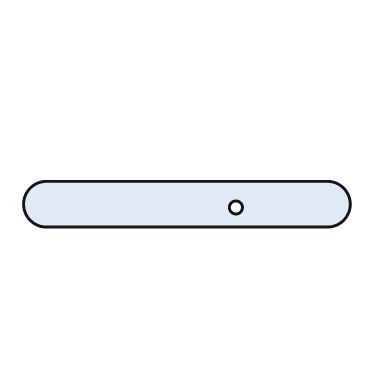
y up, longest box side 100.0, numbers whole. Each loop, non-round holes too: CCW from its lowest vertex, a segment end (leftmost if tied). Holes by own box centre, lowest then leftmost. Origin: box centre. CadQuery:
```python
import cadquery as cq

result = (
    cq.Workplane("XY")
    .moveTo(-43.0, -7.0)
    .lineTo(43.0, -7.0)
    .threePointArc((50.0, 0.0), (43.0, 7.0))
    .lineTo(-43.0, 7.0)
    .threePointArc((-50.0, 0.0), (-43.0, -7.0))
    .close()
    .moveTo(15.0, -1.0)
    .circle(2.0)
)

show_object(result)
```